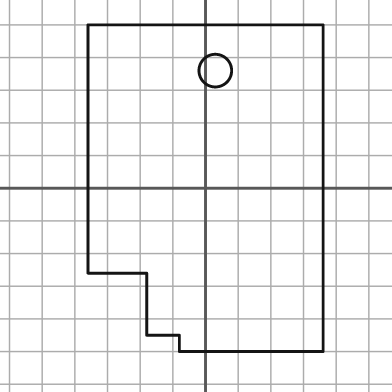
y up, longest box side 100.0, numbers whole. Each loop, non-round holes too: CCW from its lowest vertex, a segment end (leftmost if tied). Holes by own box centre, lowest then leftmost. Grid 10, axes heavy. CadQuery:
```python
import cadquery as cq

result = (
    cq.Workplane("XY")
    .moveTo(-8.0, -50.0)
    .lineTo(36.0, -50.0)
    .lineTo(36.0, 50.0)
    .lineTo(-36.0, 50.0)
    .lineTo(-36.0, -26.0)
    .lineTo(-18.0, -26.0)
    .lineTo(-18.0, -45.0)
    .lineTo(-8.0, -45.0)
    .close()
    .moveTo(3.0, 36.0)
    .circle(5.0)
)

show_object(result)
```